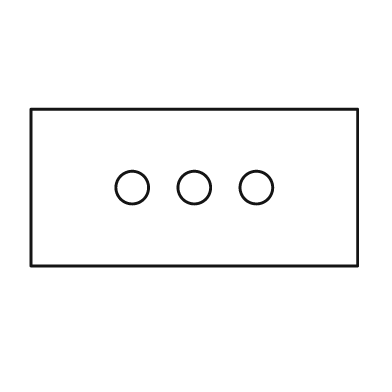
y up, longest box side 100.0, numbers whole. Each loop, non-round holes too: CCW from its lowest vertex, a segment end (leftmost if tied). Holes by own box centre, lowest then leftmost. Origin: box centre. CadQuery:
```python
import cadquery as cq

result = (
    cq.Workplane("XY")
    .moveTo(-50.0, -24.0)
    .lineTo(50.0, -24.0)
    .lineTo(50.0, 24.0)
    .lineTo(-50.0, 24.0)
    .close()
    .moveTo(-19.0, 0.0)
    .circle(5.0)
    .moveTo(0.0, 0.0)
    .circle(5.0)
    .moveTo(19.0, 0.0)
    .circle(5.0)
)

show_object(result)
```